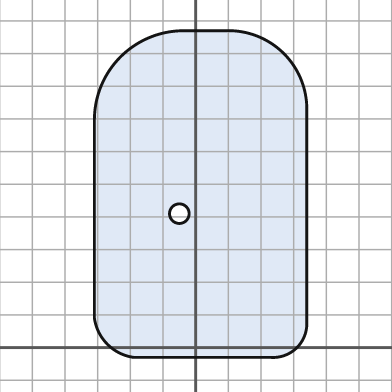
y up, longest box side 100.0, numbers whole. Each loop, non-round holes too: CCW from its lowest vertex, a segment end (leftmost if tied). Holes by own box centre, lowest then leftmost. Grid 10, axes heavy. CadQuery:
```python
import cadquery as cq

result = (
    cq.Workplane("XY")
    .moveTo(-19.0, -3.0)
    .lineTo(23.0, -3.0)
    .threePointArc((31.0, 0.0), (34.0, 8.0))
    .lineTo(34.0, 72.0)
    .threePointArc((27.0, 90.0), (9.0, 97.0))
    .lineTo(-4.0, 97.0)
    .threePointArc((-23.0, 89.0), (-31.0, 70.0))
    .lineTo(-31.0, 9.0)
    .threePointArc((-27.0, 1.0), (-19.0, -3.0))
    .close()
    .moveTo(-5.0, 41.0)
    .circle(3.0)
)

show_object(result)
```